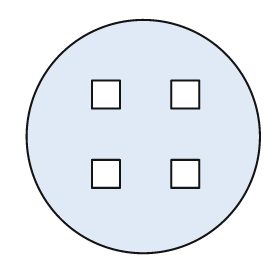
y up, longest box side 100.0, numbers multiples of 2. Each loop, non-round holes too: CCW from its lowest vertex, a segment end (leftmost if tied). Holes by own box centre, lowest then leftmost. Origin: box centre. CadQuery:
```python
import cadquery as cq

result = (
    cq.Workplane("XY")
    .moveTo(0.0, 0.0)
    .circle(50.0)
    .moveTo(-22.0, -22.0)
    .lineTo(-10.0, -22.0)
    .lineTo(-10.0, -10.0)
    .lineTo(-22.0, -10.0)
    .close()
    .moveTo(12.0, -22.0)
    .lineTo(24.0, -22.0)
    .lineTo(24.0, -10.0)
    .lineTo(12.0, -10.0)
    .close()
    .moveTo(-22.0, 12.0)
    .lineTo(-10.0, 12.0)
    .lineTo(-10.0, 24.0)
    .lineTo(-22.0, 24.0)
    .close()
    .moveTo(12.0, 12.0)
    .lineTo(24.0, 12.0)
    .lineTo(24.0, 24.0)
    .lineTo(12.0, 24.0)
    .close()
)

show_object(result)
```